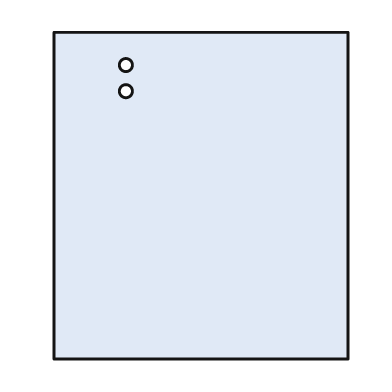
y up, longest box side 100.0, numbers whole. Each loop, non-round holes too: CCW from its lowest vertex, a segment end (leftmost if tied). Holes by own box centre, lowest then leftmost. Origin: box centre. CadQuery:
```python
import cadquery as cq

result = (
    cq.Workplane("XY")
    .moveTo(-45.0, -50.0)
    .lineTo(45.0, -50.0)
    .lineTo(45.0, 50.0)
    .lineTo(-45.0, 50.0)
    .close()
    .moveTo(-23.0, 32.0)
    .circle(2.0)
    .moveTo(-23.0, 40.0)
    .circle(2.0)
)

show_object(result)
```